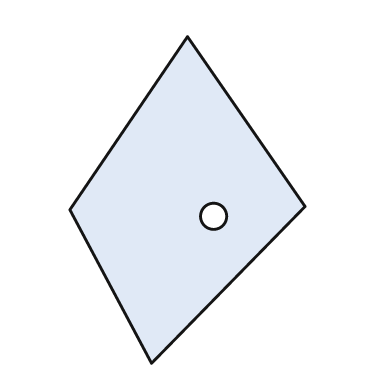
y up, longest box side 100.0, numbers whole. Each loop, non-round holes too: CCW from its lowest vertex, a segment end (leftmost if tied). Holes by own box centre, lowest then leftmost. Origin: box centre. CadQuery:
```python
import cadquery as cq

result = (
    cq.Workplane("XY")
    .moveTo(-11.0, -50.0)
    .lineTo(36.0, -2.0)
    .lineTo(0.0, 50.0)
    .lineTo(-36.0, -3.0)
    .close()
    .moveTo(8.0, -5.0)
    .circle(4.0)
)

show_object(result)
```